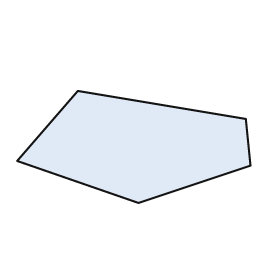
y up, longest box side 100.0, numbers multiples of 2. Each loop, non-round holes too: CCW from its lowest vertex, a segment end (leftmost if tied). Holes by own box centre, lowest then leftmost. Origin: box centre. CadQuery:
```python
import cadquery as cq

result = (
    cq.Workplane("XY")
    .moveTo(2.0, -24.0)
    .lineTo(50.0, -8.0)
    .lineTo(48.0, 12.0)
    .lineTo(-24.0, 24.0)
    .lineTo(-50.0, -6.0)
    .close()
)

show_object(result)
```